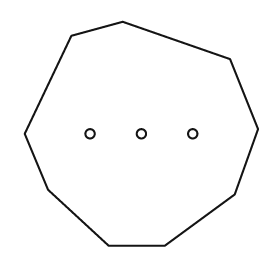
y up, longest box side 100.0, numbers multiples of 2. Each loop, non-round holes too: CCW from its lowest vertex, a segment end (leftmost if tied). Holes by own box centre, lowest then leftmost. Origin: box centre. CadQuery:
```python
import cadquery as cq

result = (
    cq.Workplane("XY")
    .moveTo(-14.0, -48.0)
    .lineTo(10.0, -48.0)
    .lineTo(40.0, -26.0)
    .lineTo(50.0, 2.0)
    .lineTo(38.0, 32.0)
    .lineTo(-8.0, 48.0)
    .lineTo(-30.0, 42.0)
    .lineTo(-50.0, 0.0)
    .lineTo(-40.0, -24.0)
    .close()
    .moveTo(-22.0, 0.0)
    .circle(2.0)
    .moveTo(0.0, 0.0)
    .circle(2.0)
    .moveTo(22.0, 0.0)
    .circle(2.0)
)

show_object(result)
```